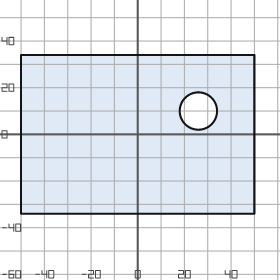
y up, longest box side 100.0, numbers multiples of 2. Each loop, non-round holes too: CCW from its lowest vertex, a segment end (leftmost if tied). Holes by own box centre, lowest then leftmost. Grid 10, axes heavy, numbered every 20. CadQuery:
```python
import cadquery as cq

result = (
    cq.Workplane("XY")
    .moveTo(-50.0, -34.0)
    .lineTo(50.0, -34.0)
    .lineTo(50.0, 34.0)
    .lineTo(-50.0, 34.0)
    .close()
    .moveTo(26.0, 10.0)
    .circle(8.0)
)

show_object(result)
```